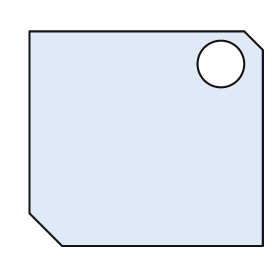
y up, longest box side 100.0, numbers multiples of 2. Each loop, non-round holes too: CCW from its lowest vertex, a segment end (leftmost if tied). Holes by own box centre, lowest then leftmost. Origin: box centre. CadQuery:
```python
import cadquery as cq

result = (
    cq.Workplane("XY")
    .moveTo(-36.0, -46.0)
    .lineTo(50.0, -46.0)
    .lineTo(50.0, 38.0)
    .lineTo(42.0, 46.0)
    .lineTo(-50.0, 46.0)
    .lineTo(-50.0, -32.0)
    .close()
    .moveTo(32.0, 32.0)
    .circle(10.0)
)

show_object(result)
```